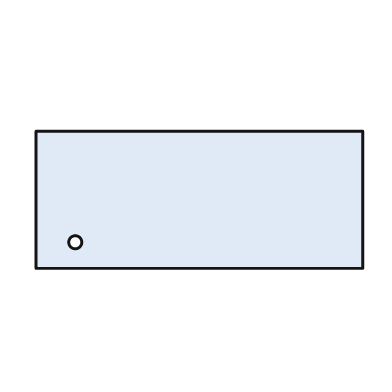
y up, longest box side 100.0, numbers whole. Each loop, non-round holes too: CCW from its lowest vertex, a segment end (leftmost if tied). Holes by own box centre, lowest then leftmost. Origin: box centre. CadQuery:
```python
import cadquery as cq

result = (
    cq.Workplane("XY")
    .moveTo(-50.0, -21.0)
    .lineTo(50.0, -21.0)
    .lineTo(50.0, 21.0)
    .lineTo(-50.0, 21.0)
    .close()
    .moveTo(-38.0, -13.0)
    .circle(2.0)
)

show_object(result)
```